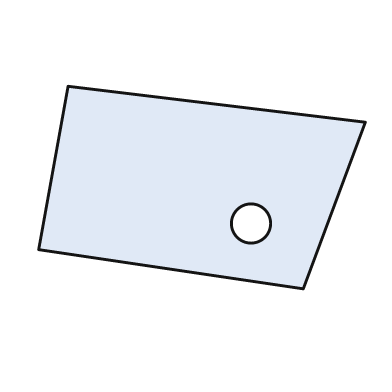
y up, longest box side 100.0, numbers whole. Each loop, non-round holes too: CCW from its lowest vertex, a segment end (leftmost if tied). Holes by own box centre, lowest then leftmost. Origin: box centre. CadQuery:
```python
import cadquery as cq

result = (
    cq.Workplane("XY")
    .moveTo(31.0, -31.0)
    .lineTo(50.0, 20.0)
    .lineTo(-41.0, 31.0)
    .lineTo(-50.0, -19.0)
    .close()
    .moveTo(15.0, -11.0)
    .circle(6.0)
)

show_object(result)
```